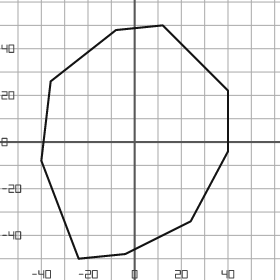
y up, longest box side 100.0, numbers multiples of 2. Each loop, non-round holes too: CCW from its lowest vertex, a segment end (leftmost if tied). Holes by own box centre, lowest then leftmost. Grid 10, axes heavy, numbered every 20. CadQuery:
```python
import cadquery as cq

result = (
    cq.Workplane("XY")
    .moveTo(-24.0, -50.0)
    .lineTo(-4.0, -48.0)
    .lineTo(24.0, -34.0)
    .lineTo(40.0, -4.0)
    .lineTo(40.0, 22.0)
    .lineTo(12.0, 50.0)
    .lineTo(-8.0, 48.0)
    .lineTo(-36.0, 26.0)
    .lineTo(-40.0, -8.0)
    .close()
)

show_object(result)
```